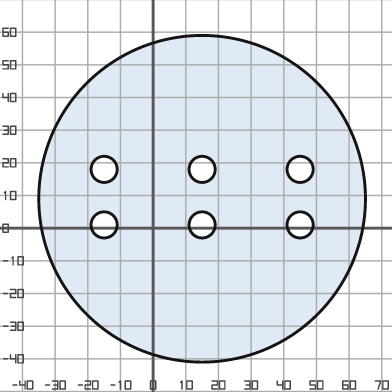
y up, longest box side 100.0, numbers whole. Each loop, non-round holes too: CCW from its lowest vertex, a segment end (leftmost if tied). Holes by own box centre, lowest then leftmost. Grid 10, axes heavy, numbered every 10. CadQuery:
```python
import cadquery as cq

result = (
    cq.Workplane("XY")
    .moveTo(15.0, 9.0)
    .circle(50.0)
    .moveTo(-15.0, 1.0)
    .circle(4.0)
    .moveTo(15.0, 1.0)
    .circle(4.0)
    .moveTo(45.0, 1.0)
    .circle(4.0)
    .moveTo(-15.0, 18.0)
    .circle(4.0)
    .moveTo(15.0, 18.0)
    .circle(4.0)
    .moveTo(45.0, 18.0)
    .circle(4.0)
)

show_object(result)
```